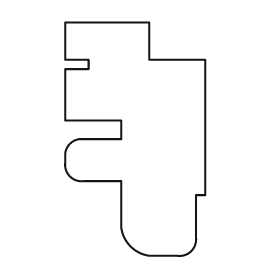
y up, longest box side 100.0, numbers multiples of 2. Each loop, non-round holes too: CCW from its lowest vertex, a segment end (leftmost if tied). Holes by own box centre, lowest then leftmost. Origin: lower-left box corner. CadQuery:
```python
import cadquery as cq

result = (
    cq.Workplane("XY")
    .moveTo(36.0, 0.0)
    .lineTo(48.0, 0.0)
    .threePointArc((54.0, 2.0), (56.0, 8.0))
    .lineTo(56.0, 26.0)
    .lineTo(60.0, 26.0)
    .lineTo(60.0, 84.0)
    .lineTo(36.0, 84.0)
    .lineTo(36.0, 100.0)
    .lineTo(0.0, 100.0)
    .lineTo(0.0, 84.0)
    .lineTo(10.0, 84.0)
    .lineTo(10.0, 80.0)
    .lineTo(0.0, 80.0)
    .lineTo(0.0, 58.0)
    .lineTo(24.0, 58.0)
    .lineTo(24.0, 50.0)
    .lineTo(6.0, 50.0)
    .threePointArc((2.0, 48.0), (0.0, 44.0))
    .lineTo(0.0, 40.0)
    .threePointArc((2.0, 34.0), (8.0, 32.0))
    .lineTo(24.0, 32.0)
    .lineTo(24.0, 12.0)
    .threePointArc((28.0, 4.0), (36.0, 0.0))
    .close()
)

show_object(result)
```